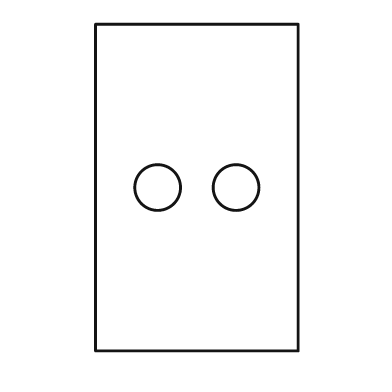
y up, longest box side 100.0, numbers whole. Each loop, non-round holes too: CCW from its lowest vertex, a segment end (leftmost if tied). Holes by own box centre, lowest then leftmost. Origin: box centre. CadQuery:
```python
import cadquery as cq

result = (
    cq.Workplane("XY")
    .moveTo(-31.0, -50.0)
    .lineTo(31.0, -50.0)
    .lineTo(31.0, 50.0)
    .lineTo(-31.0, 50.0)
    .close()
    .moveTo(-12.0, 0.0)
    .circle(7.0)
    .moveTo(12.0, 0.0)
    .circle(7.0)
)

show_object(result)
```